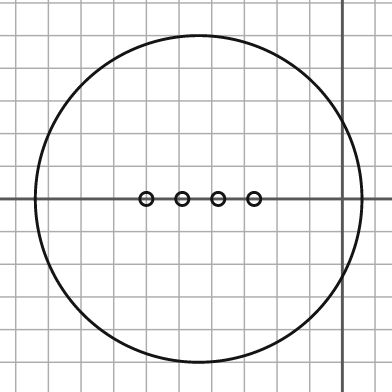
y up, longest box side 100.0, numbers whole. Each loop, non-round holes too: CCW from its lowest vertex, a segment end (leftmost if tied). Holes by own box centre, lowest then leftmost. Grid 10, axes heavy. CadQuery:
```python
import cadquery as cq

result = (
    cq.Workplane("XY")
    .moveTo(-44.0, 0.0)
    .circle(50.0)
    .moveTo(-60.0, 0.0)
    .circle(2.0)
    .moveTo(-49.0, 0.0)
    .circle(2.0)
    .moveTo(-38.0, 0.0)
    .circle(2.0)
    .moveTo(-27.0, 0.0)
    .circle(2.0)
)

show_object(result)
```